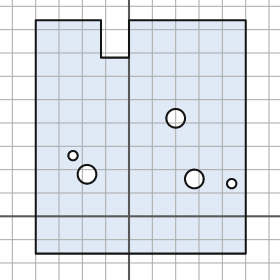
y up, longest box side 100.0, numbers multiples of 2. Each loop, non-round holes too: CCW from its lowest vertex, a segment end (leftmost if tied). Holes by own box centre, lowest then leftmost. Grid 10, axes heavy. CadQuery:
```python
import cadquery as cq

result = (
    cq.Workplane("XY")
    .moveTo(-40.0, -16.0)
    .lineTo(50.0, -16.0)
    .lineTo(50.0, 84.0)
    .lineTo(0.0, 84.0)
    .lineTo(0.0, 68.0)
    .lineTo(-12.0, 68.0)
    .lineTo(-12.0, 84.0)
    .lineTo(-40.0, 84.0)
    .close()
    .moveTo(44.0, 14.0)
    .circle(2.0)
    .moveTo(28.0, 16.0)
    .circle(4.0)
    .moveTo(-18.0, 18.0)
    .circle(4.0)
    .moveTo(-24.0, 26.0)
    .circle(2.0)
    .moveTo(20.0, 42.0)
    .circle(4.0)
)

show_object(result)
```